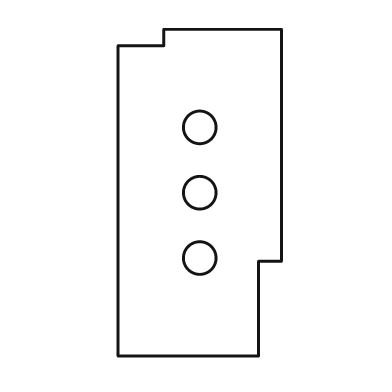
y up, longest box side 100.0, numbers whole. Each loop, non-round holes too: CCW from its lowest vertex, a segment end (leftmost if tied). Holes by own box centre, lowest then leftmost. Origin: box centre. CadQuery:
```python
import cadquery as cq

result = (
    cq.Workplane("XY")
    .moveTo(-25.0, -50.0)
    .lineTo(18.0, -50.0)
    .lineTo(18.0, -21.0)
    .lineTo(25.0, -21.0)
    .lineTo(25.0, 50.0)
    .lineTo(-11.0, 50.0)
    .lineTo(-11.0, 45.0)
    .lineTo(-25.0, 45.0)
    .close()
    .moveTo(0.0, -20.0)
    .circle(5.0)
    .moveTo(0.0, 0.0)
    .circle(5.0)
    .moveTo(0.0, 20.0)
    .circle(5.0)
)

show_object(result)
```